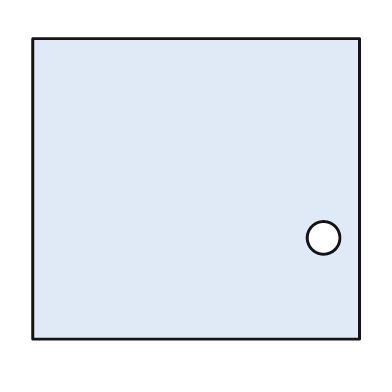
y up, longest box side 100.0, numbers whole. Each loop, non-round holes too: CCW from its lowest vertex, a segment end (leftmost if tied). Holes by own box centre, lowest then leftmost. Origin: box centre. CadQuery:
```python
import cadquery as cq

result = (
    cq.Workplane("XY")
    .moveTo(-50.0, -46.0)
    .lineTo(50.0, -46.0)
    .lineTo(50.0, 46.0)
    .lineTo(-50.0, 46.0)
    .close()
    .moveTo(39.0, -15.0)
    .circle(5.0)
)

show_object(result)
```